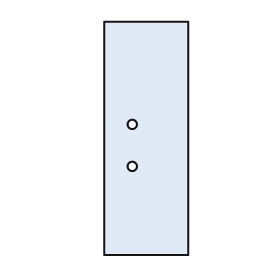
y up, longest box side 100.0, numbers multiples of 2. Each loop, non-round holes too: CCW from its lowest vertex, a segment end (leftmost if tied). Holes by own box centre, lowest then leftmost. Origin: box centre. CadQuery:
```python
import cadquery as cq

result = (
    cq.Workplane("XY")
    .moveTo(-18.0, -50.0)
    .lineTo(18.0, -50.0)
    .lineTo(18.0, 50.0)
    .lineTo(-18.0, 50.0)
    .close()
    .moveTo(-6.0, -12.0)
    .circle(2.0)
    .moveTo(-6.0, 6.0)
    .circle(2.0)
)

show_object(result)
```